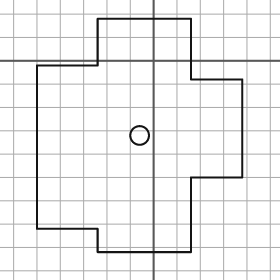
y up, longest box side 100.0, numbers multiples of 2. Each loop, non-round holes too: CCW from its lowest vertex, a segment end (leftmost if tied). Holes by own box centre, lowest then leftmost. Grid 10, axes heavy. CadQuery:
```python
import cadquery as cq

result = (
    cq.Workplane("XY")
    .moveTo(-24.0, -82.0)
    .lineTo(16.0, -82.0)
    .lineTo(16.0, -50.0)
    .lineTo(38.0, -50.0)
    .lineTo(38.0, -8.0)
    .lineTo(16.0, -8.0)
    .lineTo(16.0, 18.0)
    .lineTo(-24.0, 18.0)
    .lineTo(-24.0, -2.0)
    .lineTo(-50.0, -2.0)
    .lineTo(-50.0, -72.0)
    .lineTo(-24.0, -72.0)
    .close()
    .moveTo(-6.0, -32.0)
    .circle(4.0)
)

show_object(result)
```